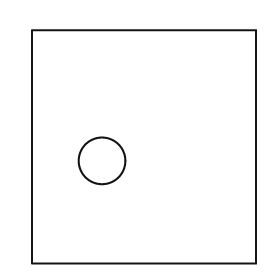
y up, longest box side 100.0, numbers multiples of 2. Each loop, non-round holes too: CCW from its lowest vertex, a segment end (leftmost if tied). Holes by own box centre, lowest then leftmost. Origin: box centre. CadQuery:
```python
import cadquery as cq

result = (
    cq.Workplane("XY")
    .moveTo(-48.0, -50.0)
    .lineTo(48.0, -50.0)
    .lineTo(48.0, 50.0)
    .lineTo(-48.0, 50.0)
    .close()
    .moveTo(-18.0, -6.0)
    .circle(10.0)
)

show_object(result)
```